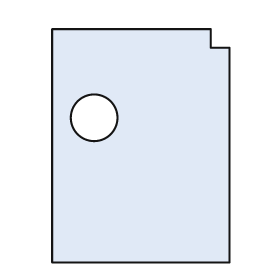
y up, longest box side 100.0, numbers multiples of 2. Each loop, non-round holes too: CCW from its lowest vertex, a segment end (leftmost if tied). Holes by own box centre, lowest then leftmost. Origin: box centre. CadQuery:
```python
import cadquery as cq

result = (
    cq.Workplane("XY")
    .moveTo(-38.0, -50.0)
    .lineTo(38.0, -50.0)
    .lineTo(38.0, 42.0)
    .lineTo(30.0, 42.0)
    .lineTo(30.0, 50.0)
    .lineTo(-38.0, 50.0)
    .close()
    .moveTo(-20.0, 12.0)
    .circle(10.0)
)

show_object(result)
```